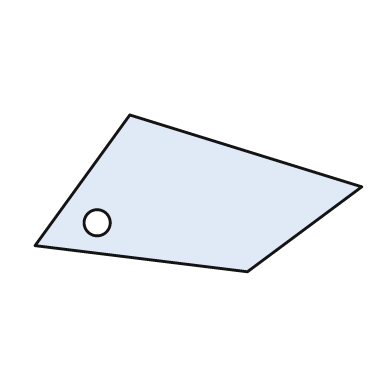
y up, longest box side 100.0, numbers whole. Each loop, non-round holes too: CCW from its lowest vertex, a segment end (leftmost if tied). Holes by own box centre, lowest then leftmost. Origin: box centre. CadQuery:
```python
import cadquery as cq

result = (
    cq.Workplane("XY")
    .moveTo(15.0, -24.0)
    .lineTo(50.0, 2.0)
    .lineTo(-21.0, 24.0)
    .lineTo(-50.0, -16.0)
    .close()
    .moveTo(-31.0, -9.0)
    .circle(4.0)
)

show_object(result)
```